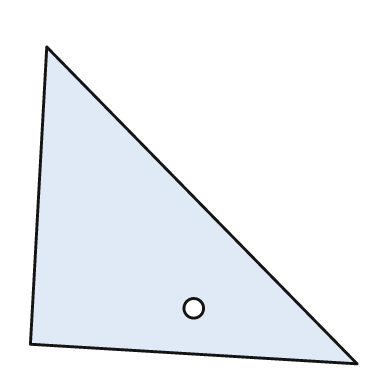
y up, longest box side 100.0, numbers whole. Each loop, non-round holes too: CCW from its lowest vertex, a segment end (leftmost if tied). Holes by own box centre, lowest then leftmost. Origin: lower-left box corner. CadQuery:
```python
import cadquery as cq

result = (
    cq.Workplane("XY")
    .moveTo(100.0, 0.0)
    .lineTo(5.0, 97.0)
    .lineTo(0.0, 6.0)
    .close()
    .moveTo(50.0, 17.0)
    .circle(3.0)
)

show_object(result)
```